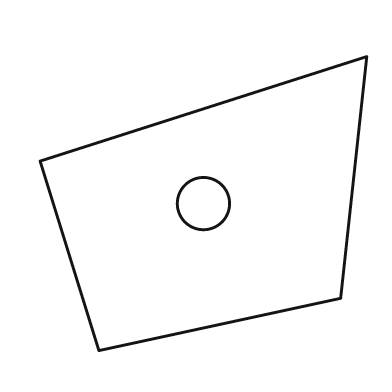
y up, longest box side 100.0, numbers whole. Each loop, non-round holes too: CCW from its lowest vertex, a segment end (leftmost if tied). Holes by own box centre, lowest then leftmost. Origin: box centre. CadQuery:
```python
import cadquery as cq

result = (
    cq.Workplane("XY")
    .moveTo(-32.0, -45.0)
    .lineTo(42.0, -29.0)
    .lineTo(50.0, 45.0)
    .lineTo(-50.0, 13.0)
    .close()
    .moveTo(0.0, 0.0)
    .circle(8.0)
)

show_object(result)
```